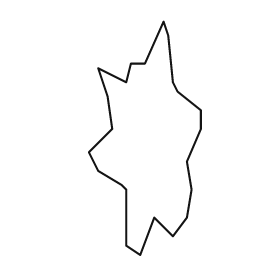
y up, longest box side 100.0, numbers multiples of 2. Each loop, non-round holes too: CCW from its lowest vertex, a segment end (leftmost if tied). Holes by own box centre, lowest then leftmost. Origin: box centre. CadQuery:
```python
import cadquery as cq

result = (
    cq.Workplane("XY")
    .moveTo(-2.0, -50.0)
    .lineTo(4.0, -34.0)
    .lineTo(12.0, -42.0)
    .lineTo(18.0, -34.0)
    .lineTo(20.0, -22.0)
    .lineTo(18.0, -10.0)
    .lineTo(24.0, 4.0)
    .lineTo(24.0, 12.0)
    .lineTo(14.0, 20.0)
    .lineTo(12.0, 24.0)
    .lineTo(10.0, 44.0)
    .lineTo(8.0, 50.0)
    .lineTo(0.0, 32.0)
    .lineTo(-6.0, 32.0)
    .lineTo(-8.0, 24.0)
    .lineTo(-20.0, 30.0)
    .lineTo(-16.0, 18.0)
    .lineTo(-14.0, 4.0)
    .lineTo(-24.0, -6.0)
    .lineTo(-20.0, -14.0)
    .lineTo(-10.0, -20.0)
    .lineTo(-8.0, -22.0)
    .lineTo(-8.0, -46.0)
    .close()
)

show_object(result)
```